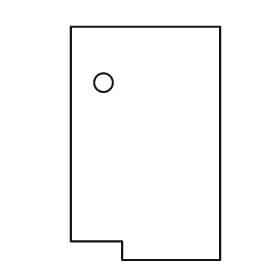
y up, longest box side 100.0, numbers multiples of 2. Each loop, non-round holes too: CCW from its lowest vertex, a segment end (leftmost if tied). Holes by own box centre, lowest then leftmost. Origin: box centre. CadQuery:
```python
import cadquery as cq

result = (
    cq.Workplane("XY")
    .moveTo(-10.0, -50.0)
    .lineTo(32.0, -50.0)
    .lineTo(32.0, 50.0)
    .lineTo(-32.0, 50.0)
    .lineTo(-32.0, -42.0)
    .lineTo(-10.0, -42.0)
    .close()
    .moveTo(-18.0, 26.0)
    .circle(4.0)
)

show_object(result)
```